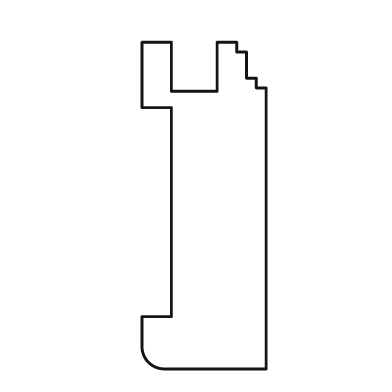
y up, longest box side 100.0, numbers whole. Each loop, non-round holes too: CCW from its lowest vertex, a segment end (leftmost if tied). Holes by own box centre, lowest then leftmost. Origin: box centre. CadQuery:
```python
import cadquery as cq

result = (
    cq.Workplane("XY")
    .moveTo(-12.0, -50.0)
    .lineTo(19.0, -50.0)
    .lineTo(19.0, 36.0)
    .lineTo(16.0, 36.0)
    .lineTo(16.0, 39.0)
    .lineTo(13.0, 39.0)
    .lineTo(13.0, 47.0)
    .lineTo(10.0, 47.0)
    .lineTo(10.0, 50.0)
    .lineTo(4.0, 50.0)
    .lineTo(4.0, 35.0)
    .lineTo(-10.0, 35.0)
    .lineTo(-10.0, 50.0)
    .lineTo(-19.0, 50.0)
    .lineTo(-19.0, 30.0)
    .lineTo(-10.0, 30.0)
    .lineTo(-10.0, -34.0)
    .lineTo(-19.0, -34.0)
    .lineTo(-19.0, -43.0)
    .threePointArc((-17.0, -48.0), (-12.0, -50.0))
    .close()
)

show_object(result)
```